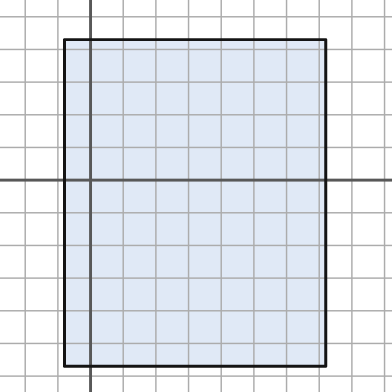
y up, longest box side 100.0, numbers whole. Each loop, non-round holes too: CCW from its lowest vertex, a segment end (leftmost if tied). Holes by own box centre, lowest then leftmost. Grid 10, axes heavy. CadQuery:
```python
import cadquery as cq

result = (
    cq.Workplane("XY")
    .moveTo(-8.0, -57.0)
    .lineTo(72.0, -57.0)
    .lineTo(72.0, 43.0)
    .lineTo(-8.0, 43.0)
    .close()
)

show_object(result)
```